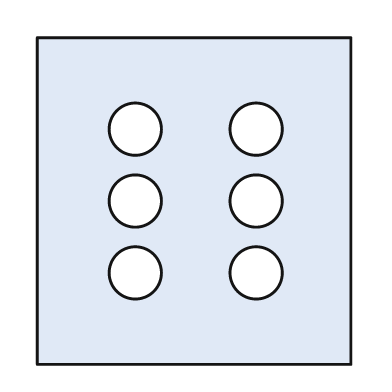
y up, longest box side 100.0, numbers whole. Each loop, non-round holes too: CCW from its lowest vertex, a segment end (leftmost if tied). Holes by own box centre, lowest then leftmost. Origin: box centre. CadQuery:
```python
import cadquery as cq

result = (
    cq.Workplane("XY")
    .moveTo(-48.0, -50.0)
    .lineTo(48.0, -50.0)
    .lineTo(48.0, 50.0)
    .lineTo(-48.0, 50.0)
    .close()
    .moveTo(-18.0, -22.0)
    .circle(8.0)
    .moveTo(19.0, -22.0)
    .circle(8.0)
    .moveTo(-18.0, 0.0)
    .circle(8.0)
    .moveTo(19.0, 0.0)
    .circle(8.0)
    .moveTo(-18.0, 22.0)
    .circle(8.0)
    .moveTo(19.0, 22.0)
    .circle(8.0)
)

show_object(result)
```